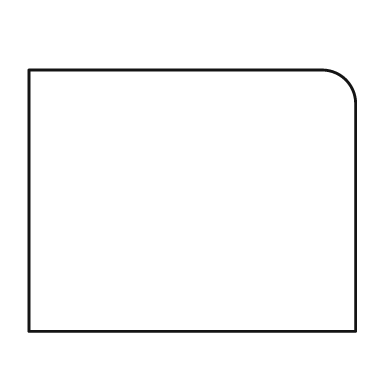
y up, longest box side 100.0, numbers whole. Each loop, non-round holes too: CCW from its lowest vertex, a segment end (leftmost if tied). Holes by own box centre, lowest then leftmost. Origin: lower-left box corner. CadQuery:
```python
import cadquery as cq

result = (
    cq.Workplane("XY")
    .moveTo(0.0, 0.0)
    .lineTo(100.0, 0.0)
    .lineTo(100.0, 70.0)
    .threePointArc((97.0, 77.0), (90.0, 80.0))
    .lineTo(0.0, 80.0)
    .close()
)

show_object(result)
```